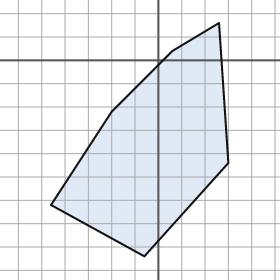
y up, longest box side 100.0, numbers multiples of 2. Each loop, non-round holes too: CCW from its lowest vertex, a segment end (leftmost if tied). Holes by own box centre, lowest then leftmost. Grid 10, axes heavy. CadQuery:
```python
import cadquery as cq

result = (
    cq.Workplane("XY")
    .moveTo(-6.0, -84.0)
    .lineTo(30.0, -44.0)
    .lineTo(26.0, 16.0)
    .lineTo(6.0, 4.0)
    .lineTo(-20.0, -22.0)
    .lineTo(-46.0, -62.0)
    .close()
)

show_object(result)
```